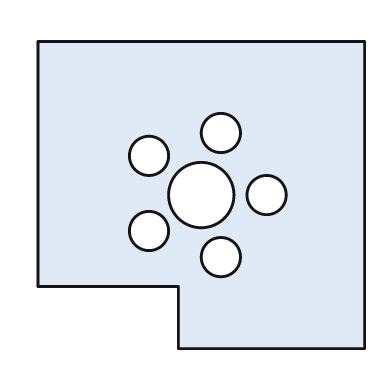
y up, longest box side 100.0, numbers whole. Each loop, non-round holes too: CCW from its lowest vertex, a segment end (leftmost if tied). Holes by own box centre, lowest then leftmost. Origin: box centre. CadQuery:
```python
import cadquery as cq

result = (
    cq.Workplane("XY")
    .moveTo(-7.0, -47.0)
    .lineTo(50.0, -47.0)
    .lineTo(50.0, 47.0)
    .lineTo(-50.0, 47.0)
    .lineTo(-50.0, -28.0)
    .lineTo(-7.0, -28.0)
    .close()
    .moveTo(6.0, -19.0)
    .circle(6.0)
    .moveTo(-16.0, -11.0)
    .circle(6.0)
    .moveTo(0.0, 0.0)
    .circle(10.0)
    .moveTo(20.0, 0.0)
    .circle(6.0)
    .moveTo(-16.0, 12.0)
    .circle(6.0)
    .moveTo(6.0, 19.0)
    .circle(6.0)
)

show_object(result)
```